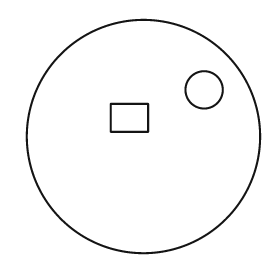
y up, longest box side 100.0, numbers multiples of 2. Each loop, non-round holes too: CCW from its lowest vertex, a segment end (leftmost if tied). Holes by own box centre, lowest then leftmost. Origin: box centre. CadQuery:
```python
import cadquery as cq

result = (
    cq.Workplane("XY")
    .moveTo(0.0, 0.0)
    .circle(50.0)
    .moveTo(-14.0, 2.0)
    .lineTo(2.0, 2.0)
    .lineTo(2.0, 14.0)
    .lineTo(-14.0, 14.0)
    .close()
    .moveTo(26.0, 20.0)
    .circle(8.0)
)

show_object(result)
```